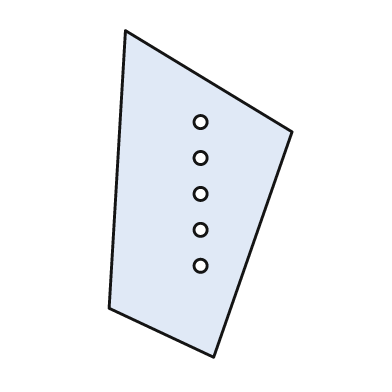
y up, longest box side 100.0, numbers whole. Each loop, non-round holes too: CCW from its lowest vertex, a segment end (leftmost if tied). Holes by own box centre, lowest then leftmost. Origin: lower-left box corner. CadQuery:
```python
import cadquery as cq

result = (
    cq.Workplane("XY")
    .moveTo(32.0, 0.0)
    .lineTo(56.0, 69.0)
    .lineTo(5.0, 100.0)
    .lineTo(0.0, 15.0)
    .close()
    .moveTo(28.0, 28.0)
    .circle(2.0)
    .moveTo(28.0, 39.0)
    .circle(2.0)
    .moveTo(28.0, 50.0)
    .circle(2.0)
    .moveTo(28.0, 61.0)
    .circle(2.0)
    .moveTo(28.0, 72.0)
    .circle(2.0)
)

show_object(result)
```